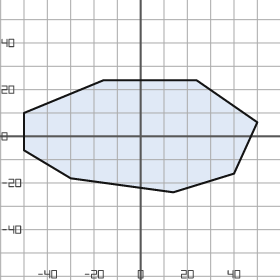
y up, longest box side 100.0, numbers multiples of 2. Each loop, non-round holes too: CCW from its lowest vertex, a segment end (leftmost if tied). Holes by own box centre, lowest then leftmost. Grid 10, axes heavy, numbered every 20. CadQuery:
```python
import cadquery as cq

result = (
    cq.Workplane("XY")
    .moveTo(14.0, -24.0)
    .lineTo(40.0, -16.0)
    .lineTo(50.0, 6.0)
    .lineTo(24.0, 24.0)
    .lineTo(-16.0, 24.0)
    .lineTo(-50.0, 10.0)
    .lineTo(-50.0, -6.0)
    .lineTo(-30.0, -18.0)
    .close()
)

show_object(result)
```